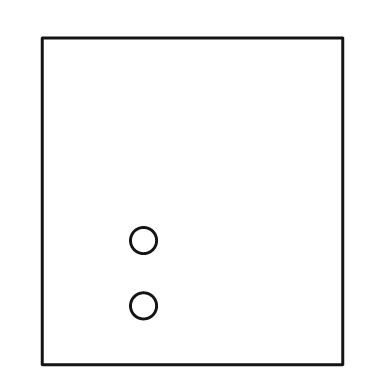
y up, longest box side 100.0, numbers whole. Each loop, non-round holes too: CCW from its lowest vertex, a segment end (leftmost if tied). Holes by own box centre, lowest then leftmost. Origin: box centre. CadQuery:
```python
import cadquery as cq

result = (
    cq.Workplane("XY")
    .moveTo(-46.0, -50.0)
    .lineTo(46.0, -50.0)
    .lineTo(46.0, 50.0)
    .lineTo(-46.0, 50.0)
    .close()
    .moveTo(-15.0, -32.0)
    .circle(4.0)
    .moveTo(-15.0, -12.0)
    .circle(4.0)
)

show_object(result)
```